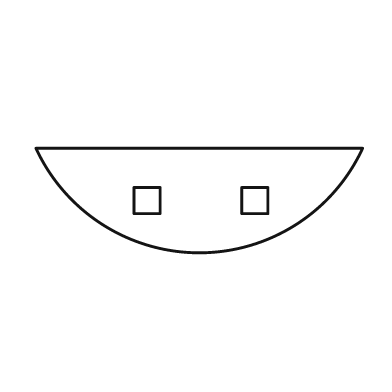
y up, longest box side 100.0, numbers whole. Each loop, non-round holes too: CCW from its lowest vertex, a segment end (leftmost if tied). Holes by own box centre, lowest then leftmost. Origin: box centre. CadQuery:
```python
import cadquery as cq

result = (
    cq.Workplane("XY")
    .moveTo(-50.0, 16.0)
    .threePointArc((0.0, -16.0), (50.0, 16.0))
    .close()
    .moveTo(-20.0, -4.0)
    .lineTo(-12.0, -4.0)
    .lineTo(-12.0, 4.0)
    .lineTo(-20.0, 4.0)
    .close()
    .moveTo(13.0, -4.0)
    .lineTo(21.0, -4.0)
    .lineTo(21.0, 4.0)
    .lineTo(13.0, 4.0)
    .close()
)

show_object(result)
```